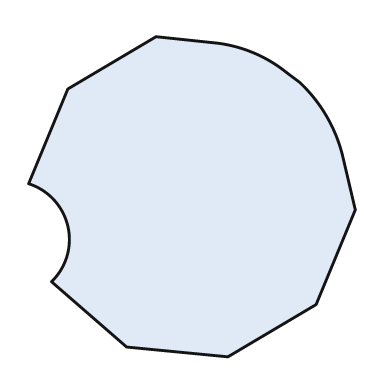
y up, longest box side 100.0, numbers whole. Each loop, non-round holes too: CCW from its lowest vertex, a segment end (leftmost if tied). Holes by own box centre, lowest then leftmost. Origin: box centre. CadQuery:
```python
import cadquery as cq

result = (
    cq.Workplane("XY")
    .moveTo(11.0, -49.0)
    .lineTo(38.0, -33.0)
    .lineTo(50.0, -4.0)
    .lineTo(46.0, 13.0)
    .threePointArc((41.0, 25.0), (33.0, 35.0))
    .lineTo(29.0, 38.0)
    .threePointArc((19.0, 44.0), (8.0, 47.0))
    .lineTo(-11.0, 49.0)
    .lineTo(-38.0, 33.0)
    .lineTo(-50.0, 4.0)
    .threePointArc((-38.0, -9.0), (-43.0, -26.0))
    .lineTo(-20.0, -46.0)
    .close()
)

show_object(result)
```